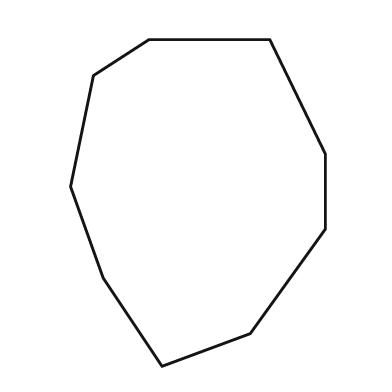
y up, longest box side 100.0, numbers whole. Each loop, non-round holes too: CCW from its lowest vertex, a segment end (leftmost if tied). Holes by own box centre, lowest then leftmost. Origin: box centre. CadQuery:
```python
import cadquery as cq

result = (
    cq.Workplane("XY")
    .moveTo(-11.0, -50.0)
    .lineTo(16.0, -40.0)
    .lineTo(39.0, -8.0)
    .lineTo(39.0, 15.0)
    .lineTo(22.0, 50.0)
    .lineTo(-15.0, 50.0)
    .lineTo(-32.0, 39.0)
    .lineTo(-39.0, 5.0)
    .lineTo(-29.0, -23.0)
    .close()
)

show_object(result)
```